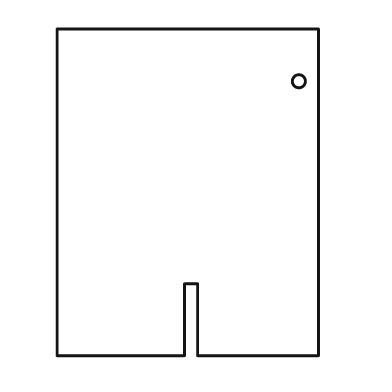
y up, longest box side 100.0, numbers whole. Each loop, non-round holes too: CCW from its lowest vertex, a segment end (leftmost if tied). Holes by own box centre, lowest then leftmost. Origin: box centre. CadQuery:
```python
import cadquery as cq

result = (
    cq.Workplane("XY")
    .moveTo(-40.0, -50.0)
    .lineTo(-1.0, -50.0)
    .lineTo(-1.0, -28.0)
    .lineTo(3.0, -28.0)
    .lineTo(3.0, -50.0)
    .lineTo(40.0, -50.0)
    .lineTo(40.0, 50.0)
    .lineTo(-40.0, 50.0)
    .close()
    .moveTo(34.0, 34.0)
    .circle(2.0)
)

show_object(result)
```